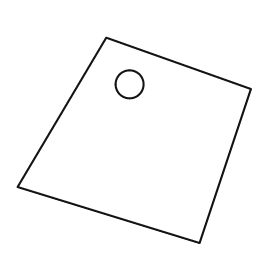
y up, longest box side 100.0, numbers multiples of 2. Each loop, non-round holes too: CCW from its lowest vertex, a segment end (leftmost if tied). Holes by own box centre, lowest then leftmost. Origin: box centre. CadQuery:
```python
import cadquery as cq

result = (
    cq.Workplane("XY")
    .moveTo(28.0, -44.0)
    .lineTo(50.0, 22.0)
    .lineTo(-12.0, 44.0)
    .lineTo(-50.0, -20.0)
    .close()
    .moveTo(-2.0, 24.0)
    .circle(6.0)
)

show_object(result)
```